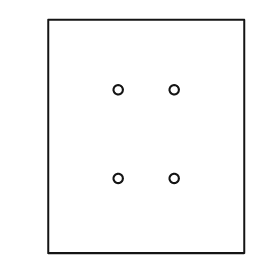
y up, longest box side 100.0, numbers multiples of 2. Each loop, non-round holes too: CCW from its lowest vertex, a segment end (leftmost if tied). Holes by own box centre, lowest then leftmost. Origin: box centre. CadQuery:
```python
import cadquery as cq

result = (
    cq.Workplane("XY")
    .moveTo(-42.0, -50.0)
    .lineTo(42.0, -50.0)
    .lineTo(42.0, 50.0)
    .lineTo(-42.0, 50.0)
    .close()
    .moveTo(-12.0, -18.0)
    .circle(2.0)
    .moveTo(12.0, -18.0)
    .circle(2.0)
    .moveTo(-12.0, 20.0)
    .circle(2.0)
    .moveTo(12.0, 20.0)
    .circle(2.0)
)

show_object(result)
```